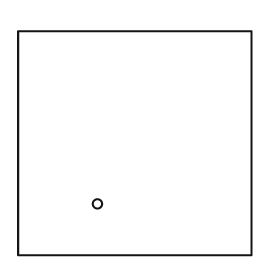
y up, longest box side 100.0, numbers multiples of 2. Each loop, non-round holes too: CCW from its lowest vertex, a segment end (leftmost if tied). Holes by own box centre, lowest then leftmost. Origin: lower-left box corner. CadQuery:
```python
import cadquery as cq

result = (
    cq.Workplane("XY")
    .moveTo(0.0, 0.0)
    .lineTo(100.0, 0.0)
    .lineTo(100.0, 96.0)
    .lineTo(0.0, 96.0)
    .close()
    .moveTo(34.0, 22.0)
    .circle(2.0)
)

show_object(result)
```